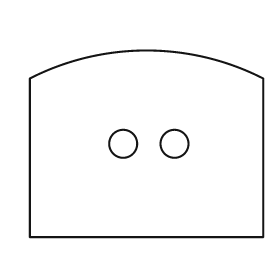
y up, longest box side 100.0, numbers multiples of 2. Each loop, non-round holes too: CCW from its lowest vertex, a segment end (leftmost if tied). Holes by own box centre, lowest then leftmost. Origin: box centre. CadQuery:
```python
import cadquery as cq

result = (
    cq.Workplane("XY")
    .moveTo(-50.0, -40.0)
    .lineTo(50.0, -40.0)
    .lineTo(50.0, 28.0)
    .threePointArc((0.0, 40.0), (-50.0, 28.0))
    .close()
    .moveTo(-10.0, 0.0)
    .circle(6.0)
    .moveTo(12.0, 0.0)
    .circle(6.0)
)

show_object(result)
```